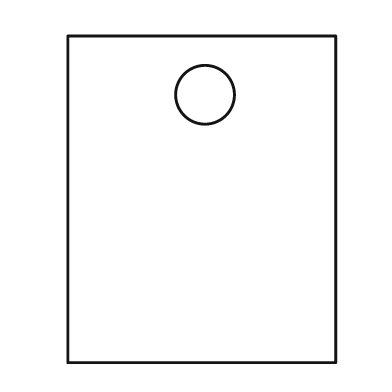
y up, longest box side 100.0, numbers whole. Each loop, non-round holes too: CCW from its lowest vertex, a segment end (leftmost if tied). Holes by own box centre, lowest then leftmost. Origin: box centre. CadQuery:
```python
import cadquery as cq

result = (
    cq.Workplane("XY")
    .moveTo(-41.0, -50.0)
    .lineTo(41.0, -50.0)
    .lineTo(41.0, 50.0)
    .lineTo(-41.0, 50.0)
    .close()
    .moveTo(1.0, 32.0)
    .circle(9.0)
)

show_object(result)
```